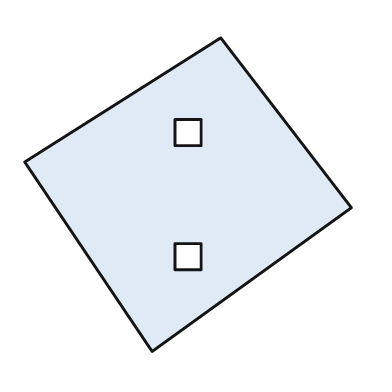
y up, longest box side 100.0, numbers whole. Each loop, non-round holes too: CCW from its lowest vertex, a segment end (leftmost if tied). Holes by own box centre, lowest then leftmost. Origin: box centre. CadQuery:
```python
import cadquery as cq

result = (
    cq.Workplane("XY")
    .moveTo(-11.0, -48.0)
    .lineTo(50.0, -4.0)
    .lineTo(10.0, 48.0)
    .lineTo(-50.0, 10.0)
    .close()
    .moveTo(-4.0, -23.0)
    .lineTo(4.0, -23.0)
    .lineTo(4.0, -15.0)
    .lineTo(-4.0, -15.0)
    .close()
    .moveTo(-4.0, 15.0)
    .lineTo(4.0, 15.0)
    .lineTo(4.0, 23.0)
    .lineTo(-4.0, 23.0)
    .close()
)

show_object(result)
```